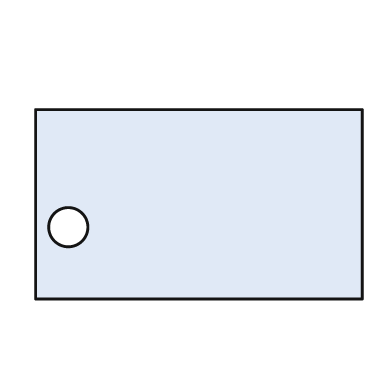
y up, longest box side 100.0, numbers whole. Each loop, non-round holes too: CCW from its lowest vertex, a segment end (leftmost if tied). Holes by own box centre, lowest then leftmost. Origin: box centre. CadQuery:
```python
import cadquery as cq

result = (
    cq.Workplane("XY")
    .moveTo(-50.0, -29.0)
    .lineTo(50.0, -29.0)
    .lineTo(50.0, 29.0)
    .lineTo(-50.0, 29.0)
    .close()
    .moveTo(-40.0, -7.0)
    .circle(6.0)
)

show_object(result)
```